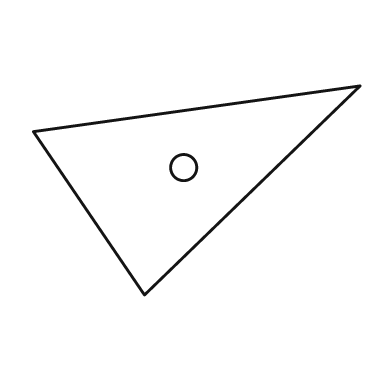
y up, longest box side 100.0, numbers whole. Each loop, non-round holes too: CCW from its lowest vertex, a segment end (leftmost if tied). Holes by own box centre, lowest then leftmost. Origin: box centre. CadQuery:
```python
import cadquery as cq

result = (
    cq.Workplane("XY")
    .moveTo(-16.0, -32.0)
    .lineTo(50.0, 32.0)
    .lineTo(-50.0, 18.0)
    .close()
    .moveTo(-4.0, 7.0)
    .circle(4.0)
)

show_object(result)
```